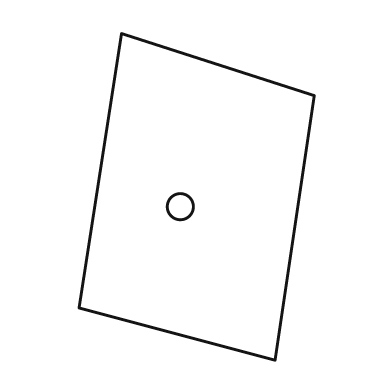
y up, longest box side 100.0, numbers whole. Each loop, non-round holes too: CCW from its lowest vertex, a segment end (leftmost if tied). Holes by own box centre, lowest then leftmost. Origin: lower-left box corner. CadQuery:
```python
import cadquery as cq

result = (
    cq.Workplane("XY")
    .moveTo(60.0, 0.0)
    .lineTo(72.0, 81.0)
    .lineTo(13.0, 100.0)
    .lineTo(0.0, 16.0)
    .close()
    .moveTo(31.0, 47.0)
    .circle(4.0)
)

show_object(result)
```